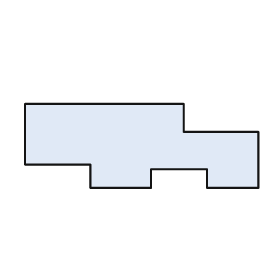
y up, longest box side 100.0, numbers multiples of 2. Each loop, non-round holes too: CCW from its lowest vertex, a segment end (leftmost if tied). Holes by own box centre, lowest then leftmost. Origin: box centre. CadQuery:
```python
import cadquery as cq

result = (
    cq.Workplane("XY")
    .moveTo(-22.0, -18.0)
    .lineTo(4.0, -18.0)
    .lineTo(4.0, -10.0)
    .lineTo(28.0, -10.0)
    .lineTo(28.0, -18.0)
    .lineTo(50.0, -18.0)
    .lineTo(50.0, 6.0)
    .lineTo(18.0, 6.0)
    .lineTo(18.0, 18.0)
    .lineTo(-50.0, 18.0)
    .lineTo(-50.0, -8.0)
    .lineTo(-22.0, -8.0)
    .close()
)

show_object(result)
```